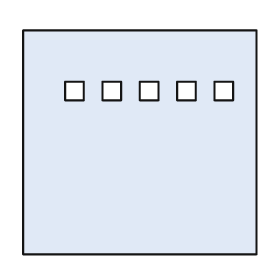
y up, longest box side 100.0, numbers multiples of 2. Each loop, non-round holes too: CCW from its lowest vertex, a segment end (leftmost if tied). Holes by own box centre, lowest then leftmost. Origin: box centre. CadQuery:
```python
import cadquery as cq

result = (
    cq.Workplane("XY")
    .moveTo(-50.0, -48.0)
    .lineTo(50.0, -48.0)
    .lineTo(50.0, 48.0)
    .lineTo(-50.0, 48.0)
    .close()
    .moveTo(-32.0, 18.0)
    .lineTo(-24.0, 18.0)
    .lineTo(-24.0, 26.0)
    .lineTo(-32.0, 26.0)
    .close()
    .moveTo(-16.0, 18.0)
    .lineTo(-8.0, 18.0)
    .lineTo(-8.0, 26.0)
    .lineTo(-16.0, 26.0)
    .close()
    .moveTo(0.0, 18.0)
    .lineTo(8.0, 18.0)
    .lineTo(8.0, 26.0)
    .lineTo(0.0, 26.0)
    .close()
    .moveTo(16.0, 18.0)
    .lineTo(24.0, 18.0)
    .lineTo(24.0, 26.0)
    .lineTo(16.0, 26.0)
    .close()
    .moveTo(32.0, 18.0)
    .lineTo(40.0, 18.0)
    .lineTo(40.0, 26.0)
    .lineTo(32.0, 26.0)
    .close()
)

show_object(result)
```